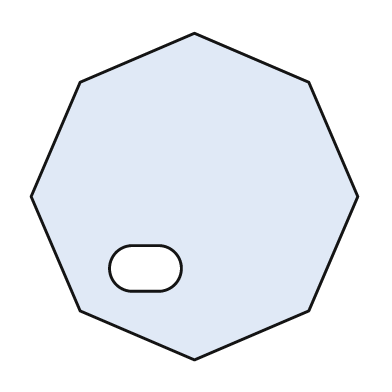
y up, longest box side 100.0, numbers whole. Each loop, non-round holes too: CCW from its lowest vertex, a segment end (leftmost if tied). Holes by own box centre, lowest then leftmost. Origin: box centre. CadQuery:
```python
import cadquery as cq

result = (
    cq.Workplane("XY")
    .moveTo(0.0, -50.0)
    .lineTo(35.0, -35.0)
    .lineTo(50.0, 0.0)
    .lineTo(35.0, 35.0)
    .lineTo(0.0, 50.0)
    .lineTo(-35.0, 35.0)
    .lineTo(-50.0, 0.0)
    .lineTo(-35.0, -35.0)
    .close()
    .moveTo(-19.0, -29.0)
    .lineTo(-11.0, -29.0)
    .threePointArc((-4.0, -22.0), (-11.0, -15.0))
    .lineTo(-19.0, -15.0)
    .threePointArc((-26.0, -22.0), (-19.0, -29.0))
    .close()
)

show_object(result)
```